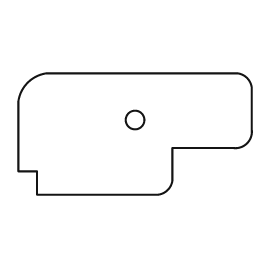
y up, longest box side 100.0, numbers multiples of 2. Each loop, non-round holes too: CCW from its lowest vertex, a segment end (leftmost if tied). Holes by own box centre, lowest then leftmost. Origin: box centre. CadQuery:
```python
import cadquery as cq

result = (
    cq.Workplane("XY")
    .moveTo(-42.0, -26.0)
    .lineTo(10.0, -26.0)
    .threePointArc((14.0, -24.0), (16.0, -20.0))
    .lineTo(16.0, -6.0)
    .lineTo(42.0, -6.0)
    .threePointArc((48.0, -4.0), (50.0, 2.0))
    .lineTo(50.0, 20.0)
    .threePointArc((48.0, 24.0), (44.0, 26.0))
    .lineTo(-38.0, 26.0)
    .threePointArc((-46.0, 22.0), (-50.0, 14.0))
    .lineTo(-50.0, -16.0)
    .lineTo(-42.0, -16.0)
    .close()
    .moveTo(0.0, 6.0)
    .circle(4.0)
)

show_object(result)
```